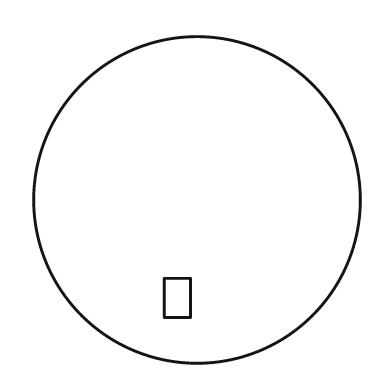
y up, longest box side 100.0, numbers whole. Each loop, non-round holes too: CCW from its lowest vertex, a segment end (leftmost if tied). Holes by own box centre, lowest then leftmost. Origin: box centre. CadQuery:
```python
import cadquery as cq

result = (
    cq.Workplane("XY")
    .moveTo(0.0, 0.0)
    .circle(50.0)
    .moveTo(-10.0, -36.0)
    .lineTo(-2.0, -36.0)
    .lineTo(-2.0, -24.0)
    .lineTo(-10.0, -24.0)
    .close()
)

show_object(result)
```